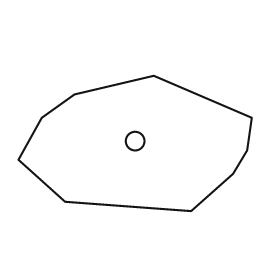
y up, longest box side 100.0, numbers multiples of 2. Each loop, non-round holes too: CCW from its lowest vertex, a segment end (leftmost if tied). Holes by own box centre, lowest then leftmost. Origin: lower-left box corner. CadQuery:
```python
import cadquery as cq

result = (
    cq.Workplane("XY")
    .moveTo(74.0, 0.0)
    .lineTo(92.0, 16.0)
    .lineTo(98.0, 26.0)
    .lineTo(100.0, 40.0)
    .lineTo(58.0, 58.0)
    .lineTo(24.0, 50.0)
    .lineTo(10.0, 40.0)
    .lineTo(0.0, 22.0)
    .lineTo(20.0, 4.0)
    .close()
    .moveTo(50.0, 30.0)
    .circle(4.0)
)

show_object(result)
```